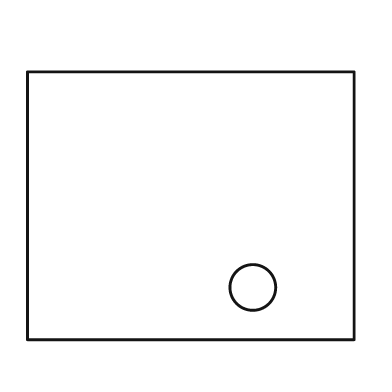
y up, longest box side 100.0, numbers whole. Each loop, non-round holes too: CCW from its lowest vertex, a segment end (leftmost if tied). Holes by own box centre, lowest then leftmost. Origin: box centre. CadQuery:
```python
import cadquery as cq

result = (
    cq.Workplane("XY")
    .moveTo(-50.0, -41.0)
    .lineTo(50.0, -41.0)
    .lineTo(50.0, 41.0)
    .lineTo(-50.0, 41.0)
    .close()
    .moveTo(19.0, -25.0)
    .circle(7.0)
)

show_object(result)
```